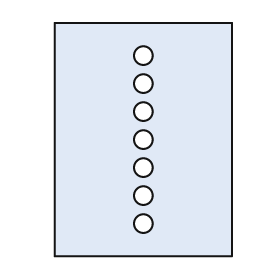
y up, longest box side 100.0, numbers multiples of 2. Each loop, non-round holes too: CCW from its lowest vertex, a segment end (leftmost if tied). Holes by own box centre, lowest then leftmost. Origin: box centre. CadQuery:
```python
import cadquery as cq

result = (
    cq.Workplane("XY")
    .moveTo(-38.0, -50.0)
    .lineTo(38.0, -50.0)
    .lineTo(38.0, 50.0)
    .lineTo(-38.0, 50.0)
    .close()
    .moveTo(0.0, -36.0)
    .circle(4.0)
    .moveTo(0.0, -24.0)
    .circle(4.0)
    .moveTo(0.0, -12.0)
    .circle(4.0)
    .moveTo(0.0, 0.0)
    .circle(4.0)
    .moveTo(0.0, 12.0)
    .circle(4.0)
    .moveTo(0.0, 24.0)
    .circle(4.0)
    .moveTo(0.0, 36.0)
    .circle(4.0)
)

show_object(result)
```